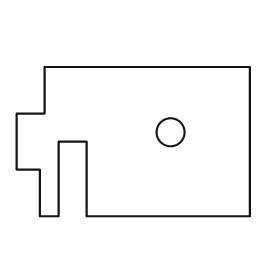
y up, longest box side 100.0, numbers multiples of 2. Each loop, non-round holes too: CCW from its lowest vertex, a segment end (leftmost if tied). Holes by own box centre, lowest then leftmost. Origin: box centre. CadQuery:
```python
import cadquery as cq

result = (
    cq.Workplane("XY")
    .moveTo(-40.0, -32.0)
    .lineTo(-32.0, -32.0)
    .lineTo(-32.0, 0.0)
    .lineTo(-20.0, 0.0)
    .lineTo(-20.0, -32.0)
    .lineTo(50.0, -32.0)
    .lineTo(50.0, 32.0)
    .lineTo(-38.0, 32.0)
    .lineTo(-38.0, 12.0)
    .lineTo(-50.0, 12.0)
    .lineTo(-50.0, -12.0)
    .lineTo(-40.0, -12.0)
    .close()
    .moveTo(16.0, 4.0)
    .circle(6.0)
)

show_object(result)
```